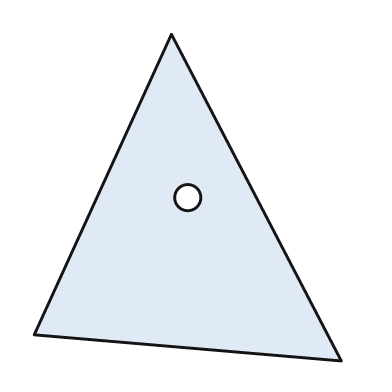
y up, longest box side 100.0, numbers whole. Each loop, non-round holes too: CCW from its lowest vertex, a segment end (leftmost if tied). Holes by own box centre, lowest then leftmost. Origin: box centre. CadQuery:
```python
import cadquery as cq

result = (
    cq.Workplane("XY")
    .moveTo(47.0, -50.0)
    .lineTo(-5.0, 50.0)
    .lineTo(-47.0, -42.0)
    .close()
    .moveTo(0.0, 0.0)
    .circle(4.0)
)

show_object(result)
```